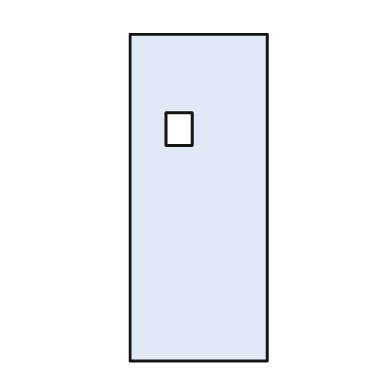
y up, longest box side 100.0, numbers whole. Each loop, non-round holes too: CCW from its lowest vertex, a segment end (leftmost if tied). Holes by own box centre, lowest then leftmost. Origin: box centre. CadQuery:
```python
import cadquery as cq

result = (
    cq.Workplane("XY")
    .moveTo(-21.0, -50.0)
    .lineTo(21.0, -50.0)
    .lineTo(21.0, 50.0)
    .lineTo(-21.0, 50.0)
    .close()
    .moveTo(-10.0, 16.0)
    .lineTo(-2.0, 16.0)
    .lineTo(-2.0, 26.0)
    .lineTo(-10.0, 26.0)
    .close()
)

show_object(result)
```